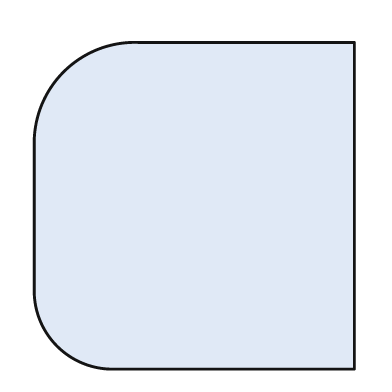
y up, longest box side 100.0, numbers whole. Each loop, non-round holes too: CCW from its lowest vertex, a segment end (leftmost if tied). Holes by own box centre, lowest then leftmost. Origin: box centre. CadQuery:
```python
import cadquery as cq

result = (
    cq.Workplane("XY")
    .moveTo(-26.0, -50.0)
    .lineTo(49.0, -50.0)
    .lineTo(49.0, 50.0)
    .lineTo(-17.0, 50.0)
    .threePointArc((-40.0, 41.0), (-49.0, 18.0))
    .lineTo(-49.0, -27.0)
    .threePointArc((-42.0, -43.0), (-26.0, -50.0))
    .close()
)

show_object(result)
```